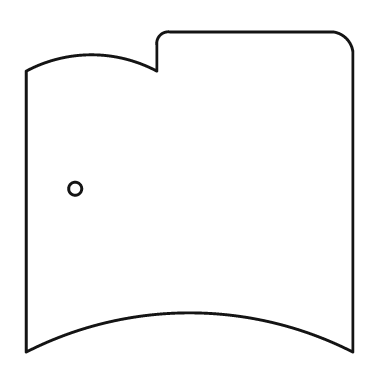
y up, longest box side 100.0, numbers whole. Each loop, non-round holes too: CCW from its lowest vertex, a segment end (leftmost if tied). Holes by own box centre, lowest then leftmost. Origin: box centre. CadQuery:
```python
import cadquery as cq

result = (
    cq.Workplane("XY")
    .moveTo(-50.0, -49.0)
    .threePointArc((0.0, -37.0), (50.0, -49.0))
    .lineTo(50.0, 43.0)
    .threePointArc((48.0, 47.0), (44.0, 49.0))
    .lineTo(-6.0, 49.0)
    .threePointArc((-9.0, 48.0), (-10.0, 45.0))
    .lineTo(-10.0, 37.0)
    .threePointArc((-30.0, 42.0), (-50.0, 37.0))
    .close()
    .moveTo(-35.0, 1.0)
    .circle(2.0)
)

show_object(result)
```